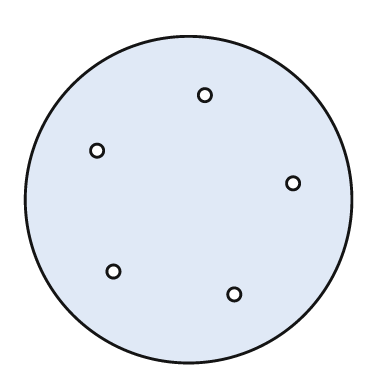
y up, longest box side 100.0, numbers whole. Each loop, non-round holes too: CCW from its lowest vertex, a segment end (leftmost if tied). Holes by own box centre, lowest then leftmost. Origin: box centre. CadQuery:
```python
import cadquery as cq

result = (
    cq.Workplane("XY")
    .moveTo(0.0, 0.0)
    .circle(50.0)
    .moveTo(14.0, -29.0)
    .circle(2.0)
    .moveTo(-23.0, -22.0)
    .circle(2.0)
    .moveTo(32.0, 5.0)
    .circle(2.0)
    .moveTo(-28.0, 15.0)
    .circle(2.0)
    .moveTo(5.0, 32.0)
    .circle(2.0)
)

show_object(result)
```